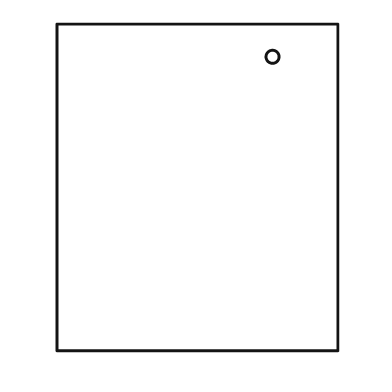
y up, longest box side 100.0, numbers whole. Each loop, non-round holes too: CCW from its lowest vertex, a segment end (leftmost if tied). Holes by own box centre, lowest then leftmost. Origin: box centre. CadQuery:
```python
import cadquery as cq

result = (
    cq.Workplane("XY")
    .moveTo(-43.0, -50.0)
    .lineTo(43.0, -50.0)
    .lineTo(43.0, 50.0)
    .lineTo(-43.0, 50.0)
    .close()
    .moveTo(23.0, 40.0)
    .circle(2.0)
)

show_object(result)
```